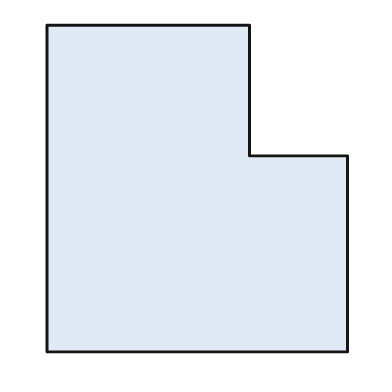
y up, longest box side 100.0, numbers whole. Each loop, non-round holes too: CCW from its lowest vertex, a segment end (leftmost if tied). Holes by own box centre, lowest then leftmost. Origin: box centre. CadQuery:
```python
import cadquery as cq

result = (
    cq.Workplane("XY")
    .moveTo(-46.0, -50.0)
    .lineTo(46.0, -50.0)
    .lineTo(46.0, 10.0)
    .lineTo(16.0, 10.0)
    .lineTo(16.0, 50.0)
    .lineTo(-46.0, 50.0)
    .close()
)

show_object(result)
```